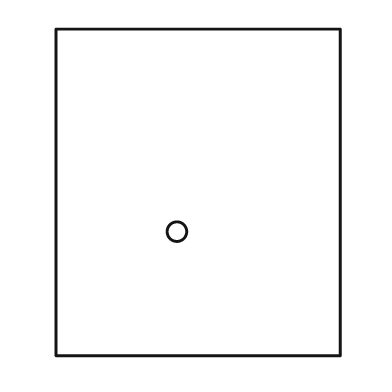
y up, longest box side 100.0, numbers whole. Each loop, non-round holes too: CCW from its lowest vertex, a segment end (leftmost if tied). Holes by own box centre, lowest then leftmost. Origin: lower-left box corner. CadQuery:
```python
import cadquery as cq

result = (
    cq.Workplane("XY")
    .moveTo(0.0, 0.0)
    .lineTo(87.0, 0.0)
    .lineTo(87.0, 100.0)
    .lineTo(0.0, 100.0)
    .close()
    .moveTo(37.0, 38.0)
    .circle(3.0)
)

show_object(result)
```